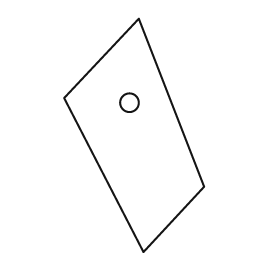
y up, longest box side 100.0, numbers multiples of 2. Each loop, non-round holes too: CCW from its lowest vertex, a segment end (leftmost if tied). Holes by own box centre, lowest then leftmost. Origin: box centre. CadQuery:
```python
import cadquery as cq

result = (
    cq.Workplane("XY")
    .moveTo(4.0, -50.0)
    .lineTo(30.0, -22.0)
    .lineTo(2.0, 50.0)
    .lineTo(-30.0, 16.0)
    .close()
    .moveTo(-2.0, 14.0)
    .circle(4.0)
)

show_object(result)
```